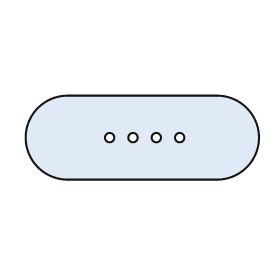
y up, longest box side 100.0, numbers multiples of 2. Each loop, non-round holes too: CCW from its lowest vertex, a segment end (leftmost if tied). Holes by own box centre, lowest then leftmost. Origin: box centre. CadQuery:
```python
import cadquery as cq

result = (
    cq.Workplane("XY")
    .moveTo(-32.0, -18.0)
    .lineTo(32.0, -18.0)
    .threePointArc((50.0, 0.0), (32.0, 18.0))
    .lineTo(-32.0, 18.0)
    .threePointArc((-50.0, 0.0), (-32.0, -18.0))
    .close()
    .moveTo(-14.0, 0.0)
    .circle(2.0)
    .moveTo(-4.0, 0.0)
    .circle(2.0)
    .moveTo(6.0, 0.0)
    .circle(2.0)
    .moveTo(16.0, 0.0)
    .circle(2.0)
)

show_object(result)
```